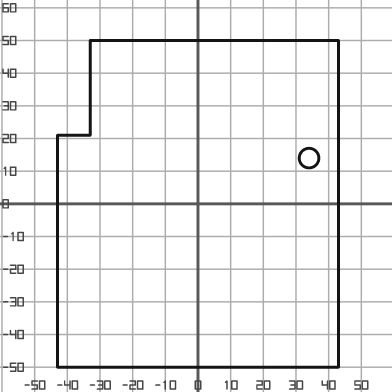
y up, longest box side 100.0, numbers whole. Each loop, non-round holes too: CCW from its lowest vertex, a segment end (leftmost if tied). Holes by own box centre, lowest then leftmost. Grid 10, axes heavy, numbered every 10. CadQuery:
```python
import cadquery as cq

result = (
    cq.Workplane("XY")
    .moveTo(-43.0, -50.0)
    .lineTo(43.0, -50.0)
    .lineTo(43.0, 50.0)
    .lineTo(-33.0, 50.0)
    .lineTo(-33.0, 21.0)
    .lineTo(-43.0, 21.0)
    .close()
    .moveTo(34.0, 14.0)
    .circle(3.0)
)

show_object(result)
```